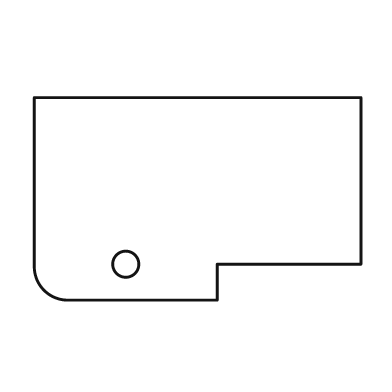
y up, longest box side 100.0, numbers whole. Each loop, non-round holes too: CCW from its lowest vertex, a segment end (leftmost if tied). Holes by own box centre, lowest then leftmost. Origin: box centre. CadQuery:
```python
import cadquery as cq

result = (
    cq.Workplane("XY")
    .moveTo(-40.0, -31.0)
    .lineTo(6.0, -31.0)
    .lineTo(6.0, -20.0)
    .lineTo(50.0, -20.0)
    .lineTo(50.0, 31.0)
    .lineTo(-50.0, 31.0)
    .lineTo(-50.0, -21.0)
    .threePointArc((-47.0, -28.0), (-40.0, -31.0))
    .close()
    .moveTo(-22.0, -20.0)
    .circle(4.0)
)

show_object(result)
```